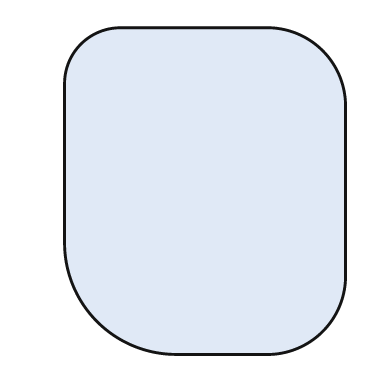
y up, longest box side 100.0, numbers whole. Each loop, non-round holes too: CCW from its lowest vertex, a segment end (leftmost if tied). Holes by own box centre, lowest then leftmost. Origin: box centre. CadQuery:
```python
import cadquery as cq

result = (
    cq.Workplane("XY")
    .moveTo(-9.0, -50.0)
    .lineTo(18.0, -50.0)
    .threePointArc((36.0, -43.0), (43.0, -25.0))
    .lineTo(43.0, 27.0)
    .threePointArc((36.0, 43.0), (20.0, 50.0))
    .lineTo(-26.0, 50.0)
    .threePointArc((-38.0, 45.0), (-43.0, 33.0))
    .lineTo(-43.0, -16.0)
    .threePointArc((-33.0, -40.0), (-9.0, -50.0))
    .close()
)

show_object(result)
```